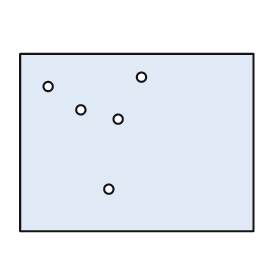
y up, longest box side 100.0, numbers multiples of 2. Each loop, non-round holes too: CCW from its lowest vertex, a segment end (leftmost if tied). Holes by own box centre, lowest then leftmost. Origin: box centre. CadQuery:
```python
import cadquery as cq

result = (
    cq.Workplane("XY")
    .moveTo(-50.0, -38.0)
    .lineTo(50.0, -38.0)
    .lineTo(50.0, 38.0)
    .lineTo(-50.0, 38.0)
    .close()
    .moveTo(-12.0, -20.0)
    .circle(2.0)
    .moveTo(-8.0, 10.0)
    .circle(2.0)
    .moveTo(-24.0, 14.0)
    .circle(2.0)
    .moveTo(-38.0, 24.0)
    .circle(2.0)
    .moveTo(2.0, 28.0)
    .circle(2.0)
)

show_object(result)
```